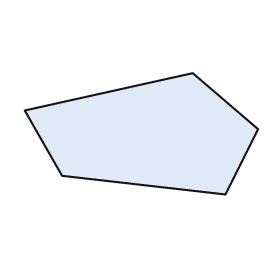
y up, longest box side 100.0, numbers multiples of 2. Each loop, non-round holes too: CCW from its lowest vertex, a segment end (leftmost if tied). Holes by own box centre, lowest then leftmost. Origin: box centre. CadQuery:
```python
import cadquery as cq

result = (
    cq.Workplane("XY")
    .moveTo(36.0, -26.0)
    .lineTo(50.0, 2.0)
    .lineTo(22.0, 26.0)
    .lineTo(-50.0, 10.0)
    .lineTo(-34.0, -18.0)
    .close()
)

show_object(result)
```